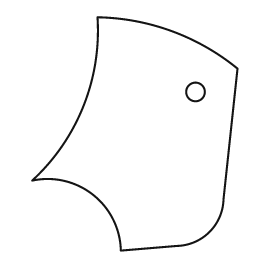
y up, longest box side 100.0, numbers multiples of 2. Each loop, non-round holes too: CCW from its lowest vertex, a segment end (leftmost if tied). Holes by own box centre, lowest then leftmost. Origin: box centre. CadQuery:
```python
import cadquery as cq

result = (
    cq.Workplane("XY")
    .moveTo(-6.0, -50.0)
    .lineTo(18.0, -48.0)
    .threePointArc((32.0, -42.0), (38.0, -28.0))
    .lineTo(44.0, 28.0)
    .threePointArc((16.0, 44.0), (-16.0, 50.0))
    .threePointArc((-22.0, 12.0), (-44.0, -20.0))
    .threePointArc((-18.0, -26.0), (-6.0, -50.0))
    .close()
    .moveTo(26.0, 18.0)
    .circle(4.0)
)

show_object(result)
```